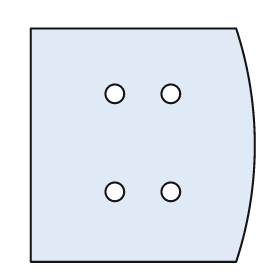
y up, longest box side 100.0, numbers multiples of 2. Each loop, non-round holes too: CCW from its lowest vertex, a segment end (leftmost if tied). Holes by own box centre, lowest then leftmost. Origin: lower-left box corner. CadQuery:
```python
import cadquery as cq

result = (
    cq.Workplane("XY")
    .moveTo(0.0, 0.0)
    .lineTo(88.0, 0.0)
    .threePointArc((96.0, 50.0), (88.0, 100.0))
    .lineTo(0.0, 100.0)
    .close()
    .moveTo(36.0, 30.0)
    .circle(4.0)
    .moveTo(60.0, 30.0)
    .circle(4.0)
    .moveTo(36.0, 72.0)
    .circle(4.0)
    .moveTo(60.0, 72.0)
    .circle(4.0)
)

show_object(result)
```